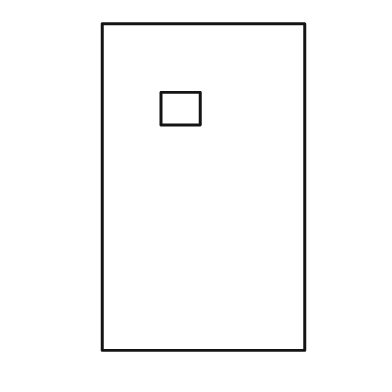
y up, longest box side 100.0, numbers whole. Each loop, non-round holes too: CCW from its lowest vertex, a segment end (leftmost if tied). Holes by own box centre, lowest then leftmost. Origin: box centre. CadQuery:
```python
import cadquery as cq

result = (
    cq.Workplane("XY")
    .moveTo(-31.0, -50.0)
    .lineTo(31.0, -50.0)
    .lineTo(31.0, 50.0)
    .lineTo(-31.0, 50.0)
    .close()
    .moveTo(-13.0, 19.0)
    .lineTo(-1.0, 19.0)
    .lineTo(-1.0, 29.0)
    .lineTo(-13.0, 29.0)
    .close()
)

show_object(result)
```